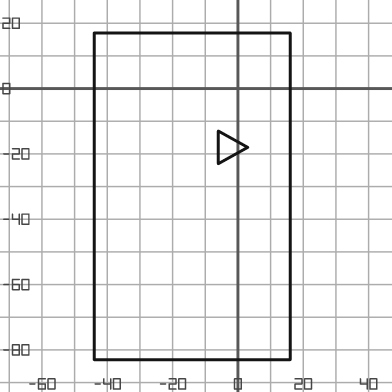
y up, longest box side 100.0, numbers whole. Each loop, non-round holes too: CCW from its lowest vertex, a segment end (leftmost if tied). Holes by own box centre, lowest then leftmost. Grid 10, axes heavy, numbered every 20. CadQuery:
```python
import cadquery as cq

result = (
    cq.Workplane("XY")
    .moveTo(-44.0, -83.0)
    .lineTo(16.0, -83.0)
    .lineTo(16.0, 17.0)
    .lineTo(-44.0, 17.0)
    .close()
    .moveTo(-6.0, -23.0)
    .lineTo(3.0, -18.0)
    .lineTo(-6.0, -13.0)
    .close()
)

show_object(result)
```